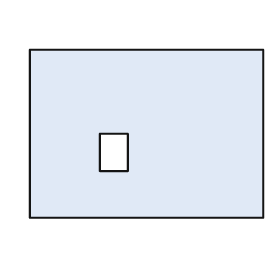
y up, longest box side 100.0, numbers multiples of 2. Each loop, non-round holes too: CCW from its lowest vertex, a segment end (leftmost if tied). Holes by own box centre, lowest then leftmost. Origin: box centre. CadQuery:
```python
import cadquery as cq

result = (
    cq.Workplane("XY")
    .moveTo(-50.0, -36.0)
    .lineTo(50.0, -36.0)
    .lineTo(50.0, 36.0)
    .lineTo(-50.0, 36.0)
    .close()
    .moveTo(-20.0, -16.0)
    .lineTo(-8.0, -16.0)
    .lineTo(-8.0, 0.0)
    .lineTo(-20.0, 0.0)
    .close()
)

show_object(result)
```